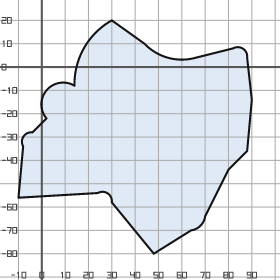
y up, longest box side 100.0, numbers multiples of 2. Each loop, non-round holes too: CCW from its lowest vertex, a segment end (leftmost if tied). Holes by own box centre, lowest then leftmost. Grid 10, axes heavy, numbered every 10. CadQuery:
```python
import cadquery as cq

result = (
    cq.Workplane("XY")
    .moveTo(48.0, -80.0)
    .lineTo(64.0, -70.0)
    .threePointArc((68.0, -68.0), (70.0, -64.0))
    .lineTo(80.0, -44.0)
    .lineTo(88.0, -36.0)
    .lineTo(90.0, -14.0)
    .lineTo(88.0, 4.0)
    .threePointArc((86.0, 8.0), (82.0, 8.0))
    .lineTo(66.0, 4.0)
    .threePointArc((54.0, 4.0), (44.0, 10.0))
    .lineTo(30.0, 20.0)
    .threePointArc((18.0, 8.0), (14.0, -8.0))
    .threePointArc((2.0, -10.0), (2.0, -22.0))
    .lineTo(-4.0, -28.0)
    .threePointArc((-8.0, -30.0), (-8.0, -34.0))
    .lineTo(-10.0, -56.0)
    .lineTo(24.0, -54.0)
    .threePointArc((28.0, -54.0), (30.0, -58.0))
    .close()
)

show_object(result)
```